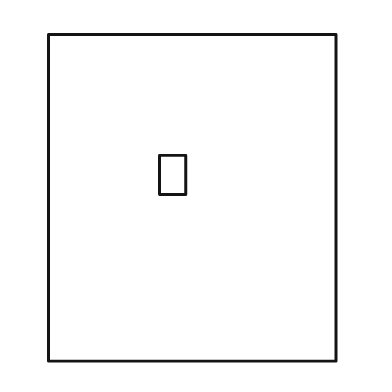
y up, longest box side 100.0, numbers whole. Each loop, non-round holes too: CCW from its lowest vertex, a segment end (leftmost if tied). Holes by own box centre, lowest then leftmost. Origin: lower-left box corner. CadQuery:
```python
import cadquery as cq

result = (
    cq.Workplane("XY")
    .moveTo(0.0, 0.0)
    .lineTo(88.0, 0.0)
    .lineTo(88.0, 100.0)
    .lineTo(0.0, 100.0)
    .close()
    .moveTo(34.0, 51.0)
    .lineTo(42.0, 51.0)
    .lineTo(42.0, 63.0)
    .lineTo(34.0, 63.0)
    .close()
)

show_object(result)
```